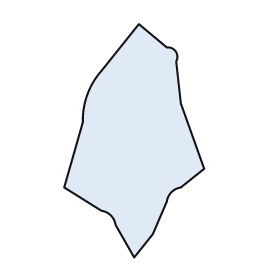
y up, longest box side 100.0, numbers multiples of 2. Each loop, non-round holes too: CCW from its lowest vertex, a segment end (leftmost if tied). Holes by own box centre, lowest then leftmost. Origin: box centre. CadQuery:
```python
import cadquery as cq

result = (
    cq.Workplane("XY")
    .moveTo(0.0, -50.0)
    .lineTo(8.0, -40.0)
    .lineTo(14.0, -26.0)
    .threePointArc((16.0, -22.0), (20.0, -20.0))
    .lineTo(30.0, -12.0)
    .lineTo(20.0, 16.0)
    .lineTo(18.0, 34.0)
    .threePointArc((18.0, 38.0), (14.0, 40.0))
    .lineTo(2.0, 50.0)
    .lineTo(-14.0, 30.0)
    .threePointArc((-20.0, 20.0), (-22.0, 8.0))
    .lineTo(-30.0, -20.0)
    .lineTo(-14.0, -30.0)
    .threePointArc((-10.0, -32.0), (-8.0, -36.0))
    .close()
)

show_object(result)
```